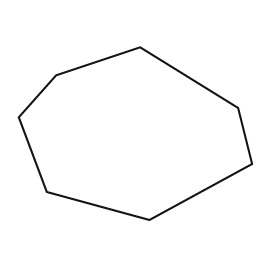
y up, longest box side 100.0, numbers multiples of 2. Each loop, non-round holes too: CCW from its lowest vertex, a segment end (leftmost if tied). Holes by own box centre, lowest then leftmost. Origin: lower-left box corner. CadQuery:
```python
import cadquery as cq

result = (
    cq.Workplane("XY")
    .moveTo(56.0, 0.0)
    .lineTo(100.0, 24.0)
    .lineTo(94.0, 48.0)
    .lineTo(52.0, 74.0)
    .lineTo(16.0, 62.0)
    .lineTo(0.0, 44.0)
    .lineTo(12.0, 12.0)
    .close()
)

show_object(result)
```